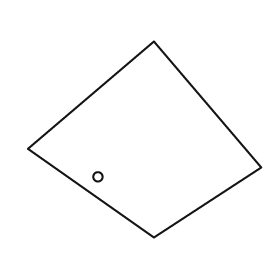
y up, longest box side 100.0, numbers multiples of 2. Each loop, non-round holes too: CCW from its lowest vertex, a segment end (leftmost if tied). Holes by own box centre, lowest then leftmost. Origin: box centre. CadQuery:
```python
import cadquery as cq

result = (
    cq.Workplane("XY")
    .moveTo(4.0, -42.0)
    .lineTo(50.0, -12.0)
    .lineTo(4.0, 42.0)
    .lineTo(-50.0, -4.0)
    .close()
    .moveTo(-20.0, -16.0)
    .circle(2.0)
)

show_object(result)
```